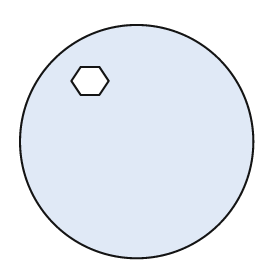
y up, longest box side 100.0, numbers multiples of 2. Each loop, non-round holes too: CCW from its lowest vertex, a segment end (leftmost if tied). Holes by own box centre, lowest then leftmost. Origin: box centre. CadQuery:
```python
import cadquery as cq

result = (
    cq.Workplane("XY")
    .moveTo(0.0, 0.0)
    .circle(50.0)
    .moveTo(-24.0, 20.0)
    .lineTo(-16.0, 20.0)
    .lineTo(-12.0, 26.0)
    .lineTo(-16.0, 32.0)
    .lineTo(-24.0, 32.0)
    .lineTo(-28.0, 26.0)
    .close()
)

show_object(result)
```